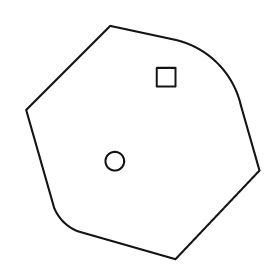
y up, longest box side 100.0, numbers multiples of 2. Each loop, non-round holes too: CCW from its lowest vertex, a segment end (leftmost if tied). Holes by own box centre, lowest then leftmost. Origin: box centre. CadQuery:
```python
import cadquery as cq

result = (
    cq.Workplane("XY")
    .moveTo(14.0, -50.0)
    .lineTo(50.0, -12.0)
    .lineTo(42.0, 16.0)
    .threePointArc((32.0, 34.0), (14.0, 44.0))
    .lineTo(-14.0, 50.0)
    .lineTo(-50.0, 14.0)
    .lineTo(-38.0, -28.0)
    .threePointArc((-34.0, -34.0), (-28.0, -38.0))
    .close()
    .moveTo(-12.0, -8.0)
    .circle(4.0)
    .moveTo(6.0, 24.0)
    .lineTo(14.0, 24.0)
    .lineTo(14.0, 32.0)
    .lineTo(6.0, 32.0)
    .close()
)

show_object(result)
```